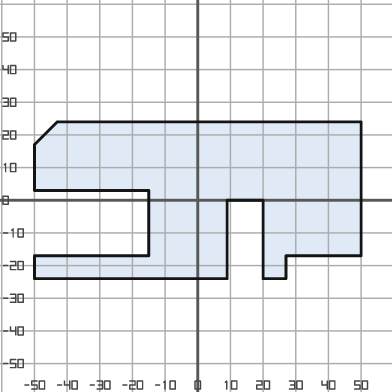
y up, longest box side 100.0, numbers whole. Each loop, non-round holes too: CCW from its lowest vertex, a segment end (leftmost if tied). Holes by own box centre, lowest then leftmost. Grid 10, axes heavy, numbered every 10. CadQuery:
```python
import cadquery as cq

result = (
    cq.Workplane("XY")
    .moveTo(-50.0, -24.0)
    .lineTo(9.0, -24.0)
    .lineTo(9.0, 0.0)
    .lineTo(20.0, 0.0)
    .lineTo(20.0, -24.0)
    .lineTo(27.0, -24.0)
    .lineTo(27.0, -17.0)
    .lineTo(50.0, -17.0)
    .lineTo(50.0, 24.0)
    .lineTo(-43.0, 24.0)
    .lineTo(-50.0, 17.0)
    .lineTo(-50.0, 3.0)
    .lineTo(-15.0, 3.0)
    .lineTo(-15.0, -17.0)
    .lineTo(-50.0, -17.0)
    .close()
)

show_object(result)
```